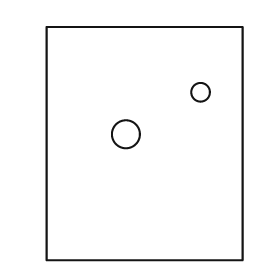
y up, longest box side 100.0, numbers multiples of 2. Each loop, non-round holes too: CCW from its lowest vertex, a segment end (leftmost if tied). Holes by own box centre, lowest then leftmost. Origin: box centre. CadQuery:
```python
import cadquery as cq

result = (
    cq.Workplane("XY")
    .moveTo(-42.0, -50.0)
    .lineTo(42.0, -50.0)
    .lineTo(42.0, 50.0)
    .lineTo(-42.0, 50.0)
    .close()
    .moveTo(-8.0, 4.0)
    .circle(6.0)
    .moveTo(24.0, 22.0)
    .circle(4.0)
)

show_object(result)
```